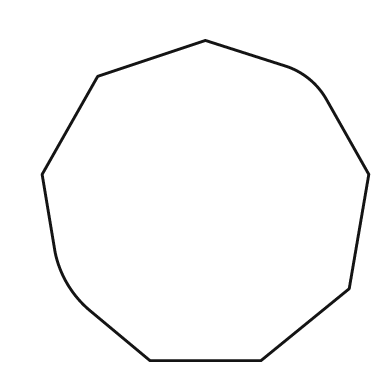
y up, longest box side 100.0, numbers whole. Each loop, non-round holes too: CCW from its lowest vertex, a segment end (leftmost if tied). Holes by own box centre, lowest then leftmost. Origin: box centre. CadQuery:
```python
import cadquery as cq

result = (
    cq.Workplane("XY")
    .moveTo(-17.0, -49.0)
    .lineTo(17.0, -49.0)
    .lineTo(44.0, -27.0)
    .lineTo(50.0, 8.0)
    .lineTo(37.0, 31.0)
    .threePointArc((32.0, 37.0), (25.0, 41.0))
    .lineTo(0.0, 49.0)
    .lineTo(-33.0, 38.0)
    .lineTo(-50.0, 8.0)
    .lineTo(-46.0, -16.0)
    .threePointArc((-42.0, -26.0), (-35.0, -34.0))
    .close()
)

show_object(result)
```